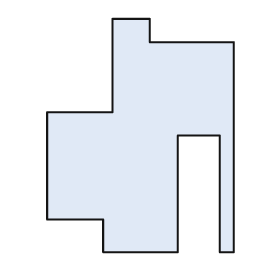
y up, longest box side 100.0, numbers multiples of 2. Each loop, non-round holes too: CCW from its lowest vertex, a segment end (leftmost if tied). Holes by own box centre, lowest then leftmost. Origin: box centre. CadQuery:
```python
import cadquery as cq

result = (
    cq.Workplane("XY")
    .moveTo(-16.0, -50.0)
    .lineTo(16.0, -50.0)
    .lineTo(16.0, 0.0)
    .lineTo(34.0, 0.0)
    .lineTo(34.0, -50.0)
    .lineTo(40.0, -50.0)
    .lineTo(40.0, 40.0)
    .lineTo(4.0, 40.0)
    .lineTo(4.0, 50.0)
    .lineTo(-12.0, 50.0)
    .lineTo(-12.0, 10.0)
    .lineTo(-40.0, 10.0)
    .lineTo(-40.0, -36.0)
    .lineTo(-16.0, -36.0)
    .close()
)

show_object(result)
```